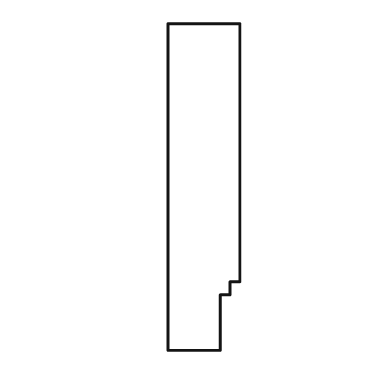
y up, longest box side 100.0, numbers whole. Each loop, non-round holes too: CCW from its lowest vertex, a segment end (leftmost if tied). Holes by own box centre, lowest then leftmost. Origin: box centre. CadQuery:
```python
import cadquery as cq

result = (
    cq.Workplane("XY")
    .moveTo(-11.0, -50.0)
    .lineTo(5.0, -50.0)
    .lineTo(5.0, -33.0)
    .lineTo(8.0, -33.0)
    .lineTo(8.0, -29.0)
    .lineTo(11.0, -29.0)
    .lineTo(11.0, 50.0)
    .lineTo(-11.0, 50.0)
    .close()
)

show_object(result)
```